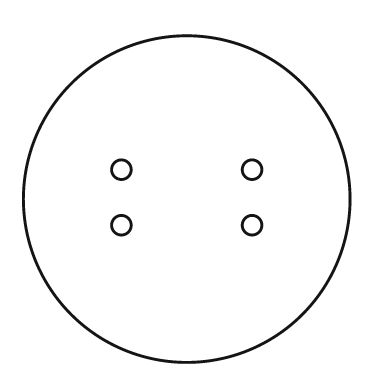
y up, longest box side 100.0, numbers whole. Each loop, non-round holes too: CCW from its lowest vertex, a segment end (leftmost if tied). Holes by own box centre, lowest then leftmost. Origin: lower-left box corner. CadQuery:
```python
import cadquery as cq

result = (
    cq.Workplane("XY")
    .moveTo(50.0, 50.0)
    .circle(50.0)
    .moveTo(30.0, 42.0)
    .circle(3.0)
    .moveTo(70.0, 42.0)
    .circle(3.0)
    .moveTo(30.0, 59.0)
    .circle(3.0)
    .moveTo(70.0, 59.0)
    .circle(3.0)
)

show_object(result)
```